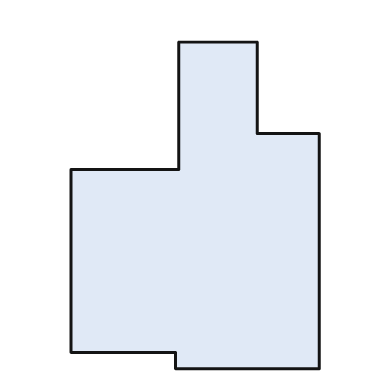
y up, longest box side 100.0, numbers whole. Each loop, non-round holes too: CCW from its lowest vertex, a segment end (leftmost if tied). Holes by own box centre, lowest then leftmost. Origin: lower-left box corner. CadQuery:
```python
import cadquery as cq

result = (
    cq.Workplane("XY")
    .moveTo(32.0, 0.0)
    .lineTo(76.0, 0.0)
    .lineTo(76.0, 72.0)
    .lineTo(57.0, 72.0)
    .lineTo(57.0, 100.0)
    .lineTo(33.0, 100.0)
    .lineTo(33.0, 61.0)
    .lineTo(0.0, 61.0)
    .lineTo(0.0, 5.0)
    .lineTo(32.0, 5.0)
    .close()
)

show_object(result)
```